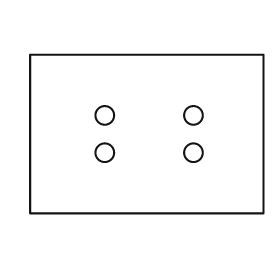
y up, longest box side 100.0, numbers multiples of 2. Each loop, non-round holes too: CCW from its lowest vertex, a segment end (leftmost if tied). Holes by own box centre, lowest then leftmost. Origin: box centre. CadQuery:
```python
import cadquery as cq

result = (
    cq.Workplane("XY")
    .moveTo(-50.0, -34.0)
    .lineTo(50.0, -34.0)
    .lineTo(50.0, 34.0)
    .lineTo(-50.0, 34.0)
    .close()
    .moveTo(-18.0, -8.0)
    .circle(4.0)
    .moveTo(20.0, -8.0)
    .circle(4.0)
    .moveTo(-18.0, 8.0)
    .circle(4.0)
    .moveTo(20.0, 8.0)
    .circle(4.0)
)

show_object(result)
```